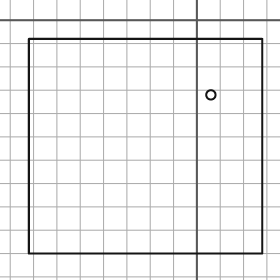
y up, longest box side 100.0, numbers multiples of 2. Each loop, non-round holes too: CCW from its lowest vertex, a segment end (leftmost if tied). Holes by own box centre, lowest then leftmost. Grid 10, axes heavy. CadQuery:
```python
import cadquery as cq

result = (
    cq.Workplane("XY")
    .moveTo(-72.0, -100.0)
    .lineTo(28.0, -100.0)
    .lineTo(28.0, -8.0)
    .lineTo(-72.0, -8.0)
    .close()
    .moveTo(6.0, -32.0)
    .circle(2.0)
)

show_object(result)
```